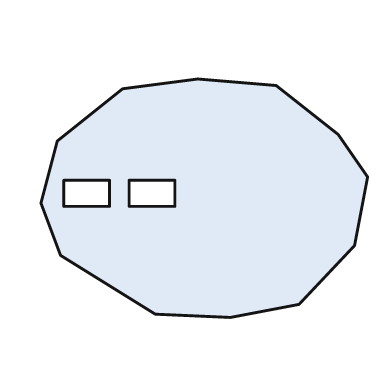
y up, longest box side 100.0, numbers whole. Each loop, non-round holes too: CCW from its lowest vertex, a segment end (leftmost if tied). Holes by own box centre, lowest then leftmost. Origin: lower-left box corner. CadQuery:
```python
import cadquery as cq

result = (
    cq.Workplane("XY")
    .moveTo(58.0, 0.0)
    .lineTo(79.0, 4.0)
    .lineTo(96.0, 22.0)
    .lineTo(100.0, 43.0)
    .lineTo(91.0, 56.0)
    .lineTo(72.0, 71.0)
    .lineTo(48.0, 73.0)
    .lineTo(25.0, 70.0)
    .lineTo(5.0, 54.0)
    .lineTo(0.0, 35.0)
    .lineTo(6.0, 19.0)
    .lineTo(35.0, 1.0)
    .close()
    .moveTo(7.0, 34.0)
    .lineTo(21.0, 34.0)
    .lineTo(21.0, 42.0)
    .lineTo(7.0, 42.0)
    .close()
    .moveTo(27.0, 34.0)
    .lineTo(41.0, 34.0)
    .lineTo(41.0, 42.0)
    .lineTo(27.0, 42.0)
    .close()
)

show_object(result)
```